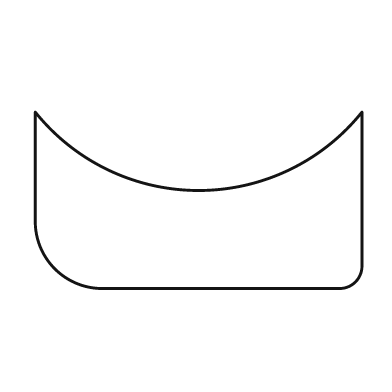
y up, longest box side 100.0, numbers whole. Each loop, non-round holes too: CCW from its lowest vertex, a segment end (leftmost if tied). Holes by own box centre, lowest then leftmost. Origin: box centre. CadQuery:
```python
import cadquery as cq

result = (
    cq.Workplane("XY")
    .moveTo(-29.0, -27.0)
    .lineTo(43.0, -27.0)
    .threePointArc((48.0, -25.0), (50.0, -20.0))
    .lineTo(50.0, 27.0)
    .threePointArc((0.0, 3.0), (-50.0, 27.0))
    .lineTo(-50.0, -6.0)
    .threePointArc((-44.0, -21.0), (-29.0, -27.0))
    .close()
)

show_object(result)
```